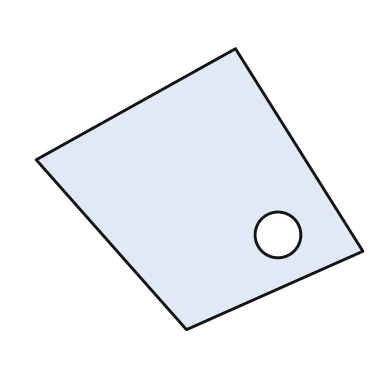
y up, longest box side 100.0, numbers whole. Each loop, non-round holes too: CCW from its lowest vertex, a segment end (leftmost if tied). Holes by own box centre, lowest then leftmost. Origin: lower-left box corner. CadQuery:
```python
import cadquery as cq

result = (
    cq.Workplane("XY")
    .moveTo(46.0, 0.0)
    .lineTo(100.0, 24.0)
    .lineTo(61.0, 86.0)
    .lineTo(0.0, 52.0)
    .close()
    .moveTo(74.0, 29.0)
    .circle(7.0)
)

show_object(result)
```